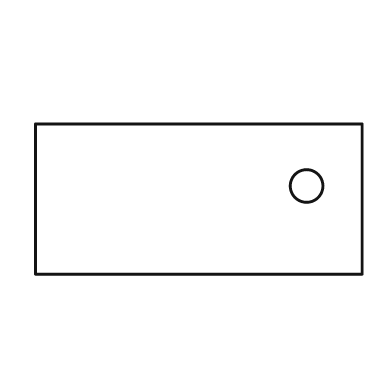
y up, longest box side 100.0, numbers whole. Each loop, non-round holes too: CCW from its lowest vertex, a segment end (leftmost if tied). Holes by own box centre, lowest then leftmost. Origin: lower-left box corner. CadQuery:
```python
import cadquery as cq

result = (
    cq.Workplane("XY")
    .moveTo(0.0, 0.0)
    .lineTo(100.0, 0.0)
    .lineTo(100.0, 46.0)
    .lineTo(0.0, 46.0)
    .close()
    .moveTo(83.0, 27.0)
    .circle(5.0)
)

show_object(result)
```